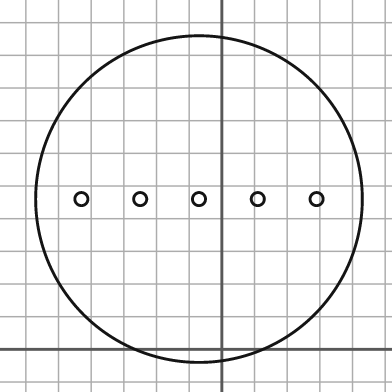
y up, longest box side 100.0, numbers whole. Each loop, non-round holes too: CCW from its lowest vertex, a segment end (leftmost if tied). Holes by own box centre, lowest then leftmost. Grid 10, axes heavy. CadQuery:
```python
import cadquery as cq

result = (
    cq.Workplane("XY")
    .moveTo(-7.0, 46.0)
    .circle(50.0)
    .moveTo(-43.0, 46.0)
    .circle(2.0)
    .moveTo(-25.0, 46.0)
    .circle(2.0)
    .moveTo(-7.0, 46.0)
    .circle(2.0)
    .moveTo(11.0, 46.0)
    .circle(2.0)
    .moveTo(29.0, 46.0)
    .circle(2.0)
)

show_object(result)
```